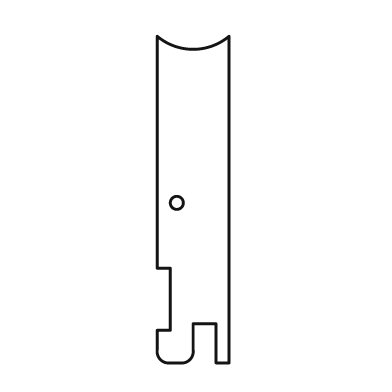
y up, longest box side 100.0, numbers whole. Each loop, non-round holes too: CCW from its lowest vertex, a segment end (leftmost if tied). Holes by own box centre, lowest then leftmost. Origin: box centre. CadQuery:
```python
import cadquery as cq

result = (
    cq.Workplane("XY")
    .moveTo(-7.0, -50.0)
    .lineTo(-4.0, -50.0)
    .threePointArc((-1.0, -49.0), (0.0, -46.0))
    .lineTo(0.0, -38.0)
    .lineTo(7.0, -38.0)
    .lineTo(7.0, -50.0)
    .lineTo(11.0, -50.0)
    .lineTo(11.0, 50.0)
    .threePointArc((0.0, 46.0), (-11.0, 50.0))
    .lineTo(-11.0, -21.0)
    .lineTo(-7.0, -21.0)
    .lineTo(-7.0, -40.0)
    .lineTo(-11.0, -40.0)
    .lineTo(-11.0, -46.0)
    .threePointArc((-10.0, -49.0), (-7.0, -50.0))
    .close()
    .moveTo(-5.0, -1.0)
    .circle(2.0)
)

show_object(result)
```